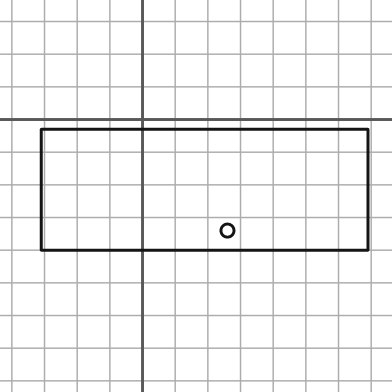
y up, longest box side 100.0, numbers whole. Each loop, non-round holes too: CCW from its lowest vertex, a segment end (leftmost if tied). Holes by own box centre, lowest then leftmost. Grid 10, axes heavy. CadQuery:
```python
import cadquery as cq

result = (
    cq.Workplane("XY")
    .moveTo(-31.0, -40.0)
    .lineTo(69.0, -40.0)
    .lineTo(69.0, -3.0)
    .lineTo(-31.0, -3.0)
    .close()
    .moveTo(26.0, -34.0)
    .circle(2.0)
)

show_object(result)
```